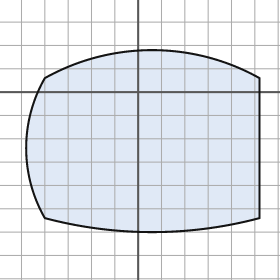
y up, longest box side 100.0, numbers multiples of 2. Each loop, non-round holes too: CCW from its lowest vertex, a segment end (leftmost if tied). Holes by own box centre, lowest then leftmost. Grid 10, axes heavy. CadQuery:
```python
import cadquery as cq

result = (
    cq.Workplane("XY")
    .moveTo(-40.0, -54.0)
    .threePointArc((6.0, -60.0), (52.0, -54.0))
    .lineTo(52.0, 6.0)
    .threePointArc((6.0, 18.0), (-40.0, 6.0))
    .threePointArc((-48.0, -24.0), (-40.0, -54.0))
    .close()
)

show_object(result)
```